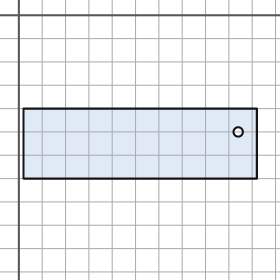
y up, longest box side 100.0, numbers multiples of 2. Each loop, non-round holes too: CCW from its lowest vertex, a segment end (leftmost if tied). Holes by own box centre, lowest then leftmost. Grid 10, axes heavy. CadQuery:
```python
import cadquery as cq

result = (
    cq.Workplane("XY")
    .moveTo(2.0, -70.0)
    .lineTo(102.0, -70.0)
    .lineTo(102.0, -40.0)
    .lineTo(2.0, -40.0)
    .close()
    .moveTo(94.0, -50.0)
    .circle(2.0)
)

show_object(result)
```